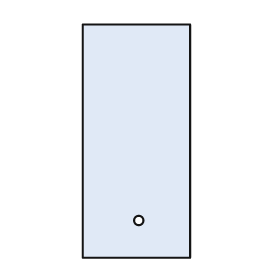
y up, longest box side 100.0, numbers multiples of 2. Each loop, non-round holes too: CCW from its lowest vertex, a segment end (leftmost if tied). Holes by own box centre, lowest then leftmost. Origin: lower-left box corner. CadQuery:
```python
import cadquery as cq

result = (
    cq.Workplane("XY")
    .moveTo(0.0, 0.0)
    .lineTo(46.0, 0.0)
    .lineTo(46.0, 100.0)
    .lineTo(0.0, 100.0)
    .close()
    .moveTo(24.0, 16.0)
    .circle(2.0)
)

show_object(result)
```